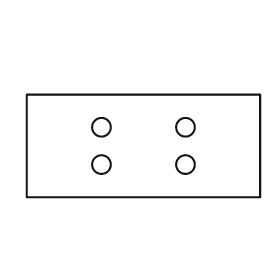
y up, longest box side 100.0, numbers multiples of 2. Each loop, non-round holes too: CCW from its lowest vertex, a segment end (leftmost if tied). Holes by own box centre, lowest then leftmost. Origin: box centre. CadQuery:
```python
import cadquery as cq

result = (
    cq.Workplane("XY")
    .moveTo(-50.0, -22.0)
    .lineTo(50.0, -22.0)
    .lineTo(50.0, 22.0)
    .lineTo(-50.0, 22.0)
    .close()
    .moveTo(-18.0, -8.0)
    .circle(4.0)
    .moveTo(18.0, -8.0)
    .circle(4.0)
    .moveTo(-18.0, 8.0)
    .circle(4.0)
    .moveTo(18.0, 8.0)
    .circle(4.0)
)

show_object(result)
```